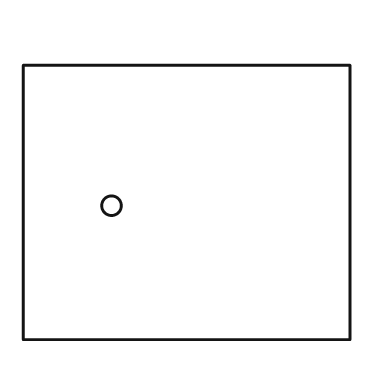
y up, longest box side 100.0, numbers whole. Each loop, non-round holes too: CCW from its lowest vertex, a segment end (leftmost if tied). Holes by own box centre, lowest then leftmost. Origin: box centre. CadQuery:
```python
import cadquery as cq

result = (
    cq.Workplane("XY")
    .moveTo(-50.0, -42.0)
    .lineTo(50.0, -42.0)
    .lineTo(50.0, 42.0)
    .lineTo(-50.0, 42.0)
    .close()
    .moveTo(-23.0, -1.0)
    .circle(3.0)
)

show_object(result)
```